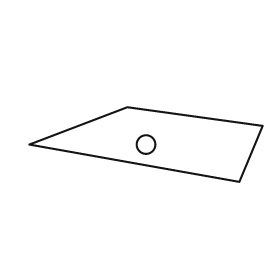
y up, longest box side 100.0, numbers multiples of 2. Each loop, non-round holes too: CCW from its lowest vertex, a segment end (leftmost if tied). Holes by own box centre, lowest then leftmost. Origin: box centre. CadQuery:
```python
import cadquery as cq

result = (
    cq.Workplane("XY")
    .moveTo(40.0, -16.0)
    .lineTo(50.0, 8.0)
    .lineTo(-8.0, 16.0)
    .lineTo(-50.0, 0.0)
    .close()
    .moveTo(0.0, 0.0)
    .circle(4.0)
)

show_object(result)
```